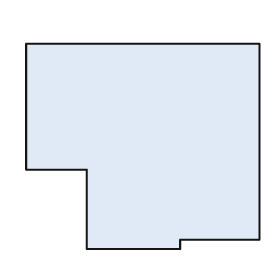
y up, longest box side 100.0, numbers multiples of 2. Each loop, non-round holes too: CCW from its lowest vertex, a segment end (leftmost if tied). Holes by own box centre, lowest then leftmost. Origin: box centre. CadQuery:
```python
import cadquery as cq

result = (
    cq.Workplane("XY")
    .moveTo(-24.0, -44.0)
    .lineTo(16.0, -44.0)
    .lineTo(16.0, -40.0)
    .lineTo(50.0, -40.0)
    .lineTo(50.0, 44.0)
    .lineTo(-50.0, 44.0)
    .lineTo(-50.0, -10.0)
    .lineTo(-24.0, -10.0)
    .close()
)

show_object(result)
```